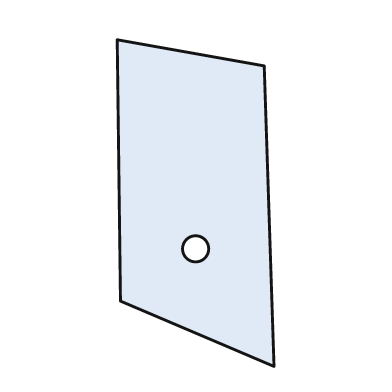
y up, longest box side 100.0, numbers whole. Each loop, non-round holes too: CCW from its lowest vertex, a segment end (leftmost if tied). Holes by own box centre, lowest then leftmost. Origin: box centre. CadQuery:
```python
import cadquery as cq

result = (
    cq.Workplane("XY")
    .moveTo(24.0, -50.0)
    .lineTo(21.0, 42.0)
    .lineTo(-24.0, 50.0)
    .lineTo(-23.0, -30.0)
    .close()
    .moveTo(0.0, -14.0)
    .circle(4.0)
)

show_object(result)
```